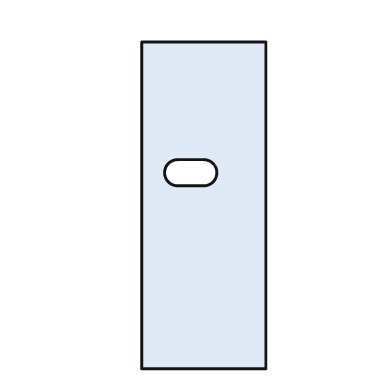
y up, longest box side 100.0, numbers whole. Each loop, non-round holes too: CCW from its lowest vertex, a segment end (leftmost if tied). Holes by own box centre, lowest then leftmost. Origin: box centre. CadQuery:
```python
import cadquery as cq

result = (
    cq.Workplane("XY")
    .moveTo(-19.0, -50.0)
    .lineTo(19.0, -50.0)
    .lineTo(19.0, 50.0)
    .lineTo(-19.0, 50.0)
    .close()
    .moveTo(-8.0, 6.0)
    .lineTo(0.0, 6.0)
    .threePointArc((4.0, 10.0), (0.0, 14.0))
    .lineTo(-8.0, 14.0)
    .threePointArc((-12.0, 10.0), (-8.0, 6.0))
    .close()
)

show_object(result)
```